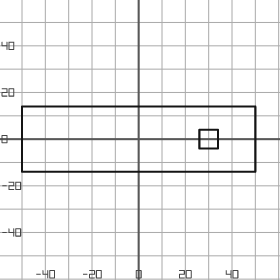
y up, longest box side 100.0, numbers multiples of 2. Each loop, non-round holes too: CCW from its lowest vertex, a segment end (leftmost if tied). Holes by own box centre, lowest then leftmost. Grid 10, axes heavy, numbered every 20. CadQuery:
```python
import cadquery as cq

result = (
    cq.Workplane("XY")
    .moveTo(-50.0, -14.0)
    .lineTo(50.0, -14.0)
    .lineTo(50.0, 14.0)
    .lineTo(-50.0, 14.0)
    .close()
    .moveTo(26.0, -4.0)
    .lineTo(34.0, -4.0)
    .lineTo(34.0, 4.0)
    .lineTo(26.0, 4.0)
    .close()
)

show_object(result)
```